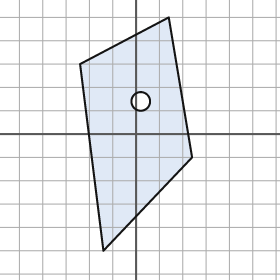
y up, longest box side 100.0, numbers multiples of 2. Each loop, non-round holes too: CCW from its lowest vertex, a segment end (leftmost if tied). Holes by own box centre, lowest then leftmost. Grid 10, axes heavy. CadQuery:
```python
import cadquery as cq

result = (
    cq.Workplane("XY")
    .moveTo(-14.0, -50.0)
    .lineTo(24.0, -10.0)
    .lineTo(14.0, 50.0)
    .lineTo(-24.0, 30.0)
    .close()
    .moveTo(2.0, 14.0)
    .circle(4.0)
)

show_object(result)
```